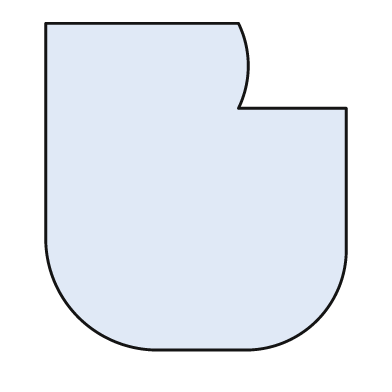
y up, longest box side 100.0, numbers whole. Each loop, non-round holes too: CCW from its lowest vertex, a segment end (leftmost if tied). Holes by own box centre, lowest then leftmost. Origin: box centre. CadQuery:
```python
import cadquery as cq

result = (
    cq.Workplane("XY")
    .moveTo(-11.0, -50.0)
    .lineTo(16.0, -50.0)
    .threePointArc((37.0, -41.0), (46.0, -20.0))
    .lineTo(46.0, 24.0)
    .lineTo(13.0, 24.0)
    .threePointArc((16.0, 37.0), (13.0, 50.0))
    .lineTo(-46.0, 50.0)
    .lineTo(-46.0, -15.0)
    .threePointArc((-36.0, -40.0), (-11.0, -50.0))
    .close()
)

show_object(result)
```